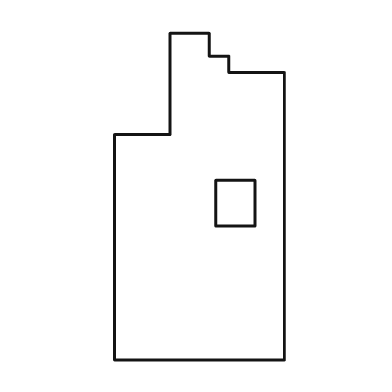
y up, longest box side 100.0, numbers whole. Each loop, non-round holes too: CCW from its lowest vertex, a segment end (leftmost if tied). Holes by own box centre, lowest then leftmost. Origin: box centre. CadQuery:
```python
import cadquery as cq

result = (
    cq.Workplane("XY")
    .moveTo(-26.0, -50.0)
    .lineTo(26.0, -50.0)
    .lineTo(26.0, 38.0)
    .lineTo(9.0, 38.0)
    .lineTo(9.0, 43.0)
    .lineTo(3.0, 43.0)
    .lineTo(3.0, 50.0)
    .lineTo(-9.0, 50.0)
    .lineTo(-9.0, 19.0)
    .lineTo(-26.0, 19.0)
    .close()
    .moveTo(5.0, -9.0)
    .lineTo(17.0, -9.0)
    .lineTo(17.0, 5.0)
    .lineTo(5.0, 5.0)
    .close()
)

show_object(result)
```